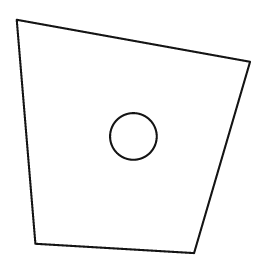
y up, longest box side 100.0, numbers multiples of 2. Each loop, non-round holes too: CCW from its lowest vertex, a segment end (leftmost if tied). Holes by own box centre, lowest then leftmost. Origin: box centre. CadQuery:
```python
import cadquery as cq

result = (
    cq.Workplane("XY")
    .moveTo(26.0, -50.0)
    .lineTo(50.0, 32.0)
    .lineTo(-50.0, 50.0)
    .lineTo(-42.0, -46.0)
    .close()
    .moveTo(0.0, 0.0)
    .circle(10.0)
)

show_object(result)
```